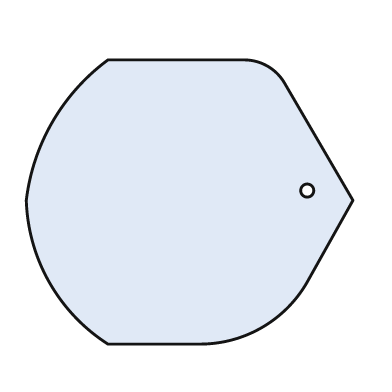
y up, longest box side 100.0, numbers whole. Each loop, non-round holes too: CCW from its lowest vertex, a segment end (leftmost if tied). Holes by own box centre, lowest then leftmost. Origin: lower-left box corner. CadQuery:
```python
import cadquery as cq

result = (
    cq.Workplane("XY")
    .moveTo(25.0, 0.0)
    .lineTo(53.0, 0.0)
    .threePointArc((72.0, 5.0), (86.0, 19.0))
    .lineTo(100.0, 44.0)
    .lineTo(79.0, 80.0)
    .threePointArc((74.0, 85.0), (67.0, 87.0))
    .lineTo(25.0, 87.0)
    .threePointArc((8.0, 68.0), (0.0, 44.0))
    .threePointArc((7.0, 19.0), (25.0, 0.0))
    .close()
    .moveTo(86.0, 47.0)
    .circle(2.0)
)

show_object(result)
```